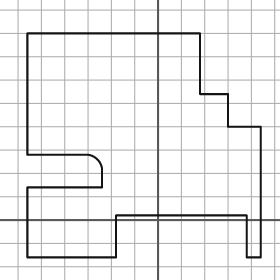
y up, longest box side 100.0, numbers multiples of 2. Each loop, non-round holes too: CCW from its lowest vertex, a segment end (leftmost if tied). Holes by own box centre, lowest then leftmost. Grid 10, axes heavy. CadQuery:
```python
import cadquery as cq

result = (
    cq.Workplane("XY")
    .moveTo(-56.0, -16.0)
    .lineTo(-18.0, -16.0)
    .lineTo(-18.0, 2.0)
    .lineTo(38.0, 2.0)
    .lineTo(38.0, -16.0)
    .lineTo(44.0, -16.0)
    .lineTo(44.0, 40.0)
    .lineTo(30.0, 40.0)
    .lineTo(30.0, 54.0)
    .lineTo(18.0, 54.0)
    .lineTo(18.0, 80.0)
    .lineTo(-56.0, 80.0)
    .lineTo(-56.0, 28.0)
    .lineTo(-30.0, 28.0)
    .threePointArc((-26.0, 26.0), (-24.0, 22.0))
    .lineTo(-24.0, 14.0)
    .lineTo(-56.0, 14.0)
    .close()
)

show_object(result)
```